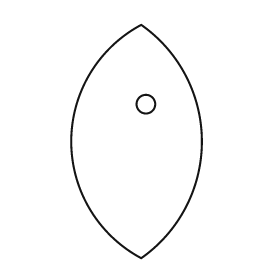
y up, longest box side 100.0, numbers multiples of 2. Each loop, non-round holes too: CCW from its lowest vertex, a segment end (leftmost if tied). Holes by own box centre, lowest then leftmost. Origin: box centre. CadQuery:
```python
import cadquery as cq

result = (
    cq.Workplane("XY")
    .moveTo(2.0, -50.0)
    .threePointArc((28.0, 0.0), (2.0, 50.0))
    .threePointArc((-28.0, 0.0), (2.0, -50.0))
    .close()
    .moveTo(4.0, 16.0)
    .circle(4.0)
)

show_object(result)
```